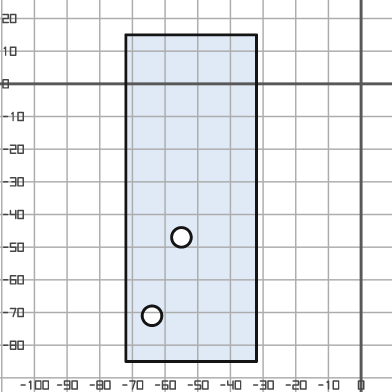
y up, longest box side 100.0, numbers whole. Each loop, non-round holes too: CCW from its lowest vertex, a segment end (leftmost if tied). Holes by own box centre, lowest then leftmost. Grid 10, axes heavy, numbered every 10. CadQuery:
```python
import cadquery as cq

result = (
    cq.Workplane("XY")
    .moveTo(-72.0, -85.0)
    .lineTo(-32.0, -85.0)
    .lineTo(-32.0, 15.0)
    .lineTo(-72.0, 15.0)
    .close()
    .moveTo(-64.0, -71.0)
    .circle(3.0)
    .moveTo(-55.0, -47.0)
    .circle(3.0)
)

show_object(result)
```